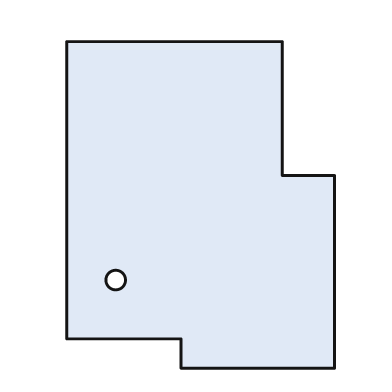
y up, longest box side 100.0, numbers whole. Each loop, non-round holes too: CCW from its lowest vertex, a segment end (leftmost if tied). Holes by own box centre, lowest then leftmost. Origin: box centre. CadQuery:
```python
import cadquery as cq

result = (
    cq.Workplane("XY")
    .moveTo(-6.0, -50.0)
    .lineTo(41.0, -50.0)
    .lineTo(41.0, 9.0)
    .lineTo(25.0, 9.0)
    .lineTo(25.0, 50.0)
    .lineTo(-41.0, 50.0)
    .lineTo(-41.0, -41.0)
    .lineTo(-6.0, -41.0)
    .close()
    .moveTo(-26.0, -23.0)
    .circle(3.0)
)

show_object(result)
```